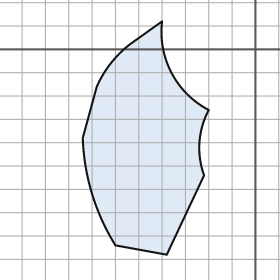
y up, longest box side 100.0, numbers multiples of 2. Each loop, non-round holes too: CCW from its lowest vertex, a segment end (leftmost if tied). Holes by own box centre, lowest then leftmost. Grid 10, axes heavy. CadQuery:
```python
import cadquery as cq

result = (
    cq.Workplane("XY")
    .moveTo(-38.0, -88.0)
    .lineTo(-22.0, -54.0)
    .threePointArc((-24.0, -40.0), (-20.0, -26.0))
    .threePointArc((-36.0, -10.0), (-40.0, 12.0))
    .lineTo(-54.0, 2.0)
    .threePointArc((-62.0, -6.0), (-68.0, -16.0))
    .lineTo(-74.0, -38.0)
    .threePointArc((-70.0, -62.0), (-60.0, -84.0))
    .close()
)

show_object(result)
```